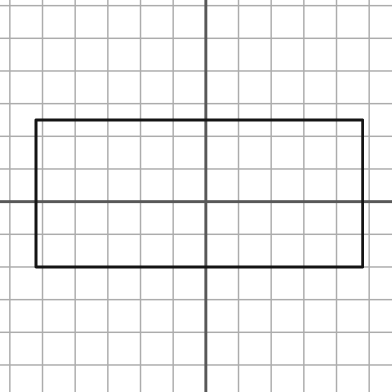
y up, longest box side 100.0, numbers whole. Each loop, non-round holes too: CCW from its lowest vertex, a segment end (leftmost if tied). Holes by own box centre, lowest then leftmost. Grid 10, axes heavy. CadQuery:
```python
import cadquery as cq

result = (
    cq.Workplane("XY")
    .moveTo(-52.0, -20.0)
    .lineTo(48.0, -20.0)
    .lineTo(48.0, 25.0)
    .lineTo(-52.0, 25.0)
    .close()
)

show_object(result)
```